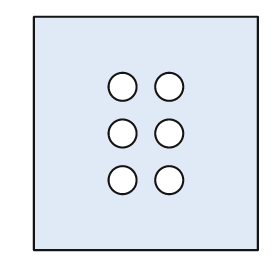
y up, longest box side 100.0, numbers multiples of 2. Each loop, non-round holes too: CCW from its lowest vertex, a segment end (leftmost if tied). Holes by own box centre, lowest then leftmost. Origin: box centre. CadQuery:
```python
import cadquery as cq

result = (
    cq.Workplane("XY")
    .moveTo(-48.0, -50.0)
    .lineTo(48.0, -50.0)
    .lineTo(48.0, 50.0)
    .lineTo(-48.0, 50.0)
    .close()
    .moveTo(-10.0, -20.0)
    .circle(6.0)
    .moveTo(10.0, -20.0)
    .circle(6.0)
    .moveTo(-10.0, 0.0)
    .circle(6.0)
    .moveTo(10.0, 0.0)
    .circle(6.0)
    .moveTo(-10.0, 20.0)
    .circle(6.0)
    .moveTo(10.0, 20.0)
    .circle(6.0)
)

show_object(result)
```